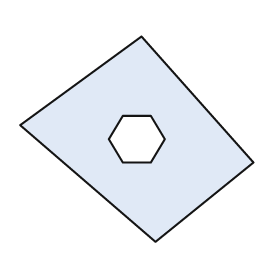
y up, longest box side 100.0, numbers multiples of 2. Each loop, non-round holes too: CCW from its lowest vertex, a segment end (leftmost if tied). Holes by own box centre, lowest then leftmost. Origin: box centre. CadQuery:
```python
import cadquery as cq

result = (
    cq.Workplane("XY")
    .moveTo(8.0, -44.0)
    .lineTo(50.0, -10.0)
    .lineTo(2.0, 44.0)
    .lineTo(-50.0, 6.0)
    .close()
    .moveTo(-6.0, -10.0)
    .lineTo(6.0, -10.0)
    .lineTo(12.0, 0.0)
    .lineTo(6.0, 10.0)
    .lineTo(-6.0, 10.0)
    .lineTo(-12.0, 0.0)
    .close()
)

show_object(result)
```